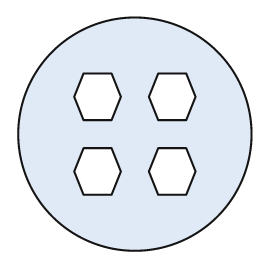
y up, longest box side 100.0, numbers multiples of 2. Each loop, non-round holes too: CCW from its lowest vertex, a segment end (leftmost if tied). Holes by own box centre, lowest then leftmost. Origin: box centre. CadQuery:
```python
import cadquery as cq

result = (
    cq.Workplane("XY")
    .moveTo(0.0, 0.0)
    .circle(50.0)
    .moveTo(-22.0, -26.0)
    .lineTo(-10.0, -26.0)
    .lineTo(-6.0, -16.0)
    .lineTo(-10.0, -6.0)
    .lineTo(-22.0, -6.0)
    .lineTo(-26.0, -16.0)
    .close()
    .moveTo(10.0, -26.0)
    .lineTo(22.0, -26.0)
    .lineTo(26.0, -16.0)
    .lineTo(22.0, -6.0)
    .lineTo(10.0, -6.0)
    .lineTo(6.0, -16.0)
    .close()
    .moveTo(-22.0, 6.0)
    .lineTo(-10.0, 6.0)
    .lineTo(-6.0, 16.0)
    .lineTo(-10.0, 26.0)
    .lineTo(-22.0, 26.0)
    .lineTo(-26.0, 16.0)
    .close()
    .moveTo(10.0, 6.0)
    .lineTo(22.0, 6.0)
    .lineTo(26.0, 16.0)
    .lineTo(22.0, 26.0)
    .lineTo(10.0, 26.0)
    .lineTo(6.0, 16.0)
    .close()
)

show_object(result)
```